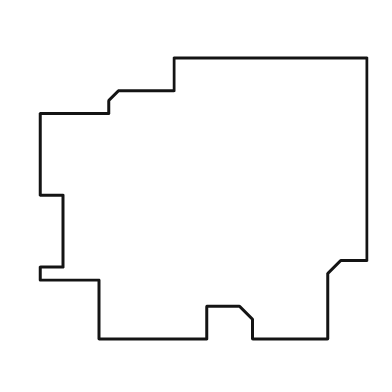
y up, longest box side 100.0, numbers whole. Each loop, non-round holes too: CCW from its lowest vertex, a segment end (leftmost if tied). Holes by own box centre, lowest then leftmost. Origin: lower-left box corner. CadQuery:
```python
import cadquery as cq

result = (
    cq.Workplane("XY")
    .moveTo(18.0, 0.0)
    .lineTo(51.0, 0.0)
    .lineTo(51.0, 10.0)
    .lineTo(61.0, 10.0)
    .lineTo(65.0, 6.0)
    .lineTo(65.0, 0.0)
    .lineTo(88.0, 0.0)
    .lineTo(88.0, 20.0)
    .lineTo(92.0, 24.0)
    .lineTo(100.0, 24.0)
    .lineTo(100.0, 86.0)
    .lineTo(41.0, 86.0)
    .lineTo(41.0, 76.0)
    .lineTo(24.0, 76.0)
    .lineTo(21.0, 73.0)
    .lineTo(21.0, 69.0)
    .lineTo(0.0, 69.0)
    .lineTo(0.0, 44.0)
    .lineTo(7.0, 44.0)
    .lineTo(7.0, 22.0)
    .lineTo(0.0, 22.0)
    .lineTo(0.0, 18.0)
    .lineTo(18.0, 18.0)
    .close()
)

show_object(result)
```